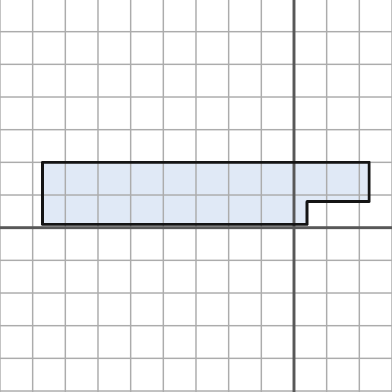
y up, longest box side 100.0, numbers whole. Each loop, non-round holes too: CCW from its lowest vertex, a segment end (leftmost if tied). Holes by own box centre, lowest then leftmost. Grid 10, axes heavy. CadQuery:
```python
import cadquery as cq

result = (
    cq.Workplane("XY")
    .moveTo(-77.0, 1.0)
    .lineTo(4.0, 1.0)
    .lineTo(4.0, 8.0)
    .lineTo(23.0, 8.0)
    .lineTo(23.0, 20.0)
    .lineTo(-77.0, 20.0)
    .close()
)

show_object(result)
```